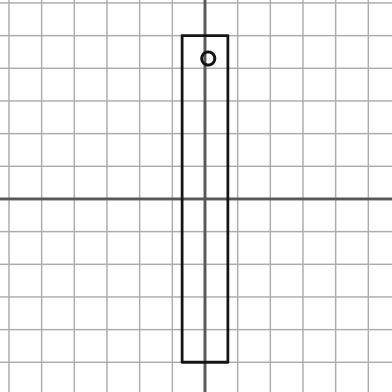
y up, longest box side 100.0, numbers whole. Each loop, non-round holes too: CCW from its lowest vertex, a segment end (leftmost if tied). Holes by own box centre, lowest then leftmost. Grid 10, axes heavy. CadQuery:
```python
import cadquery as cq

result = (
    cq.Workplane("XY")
    .moveTo(-7.0, -50.0)
    .lineTo(7.0, -50.0)
    .lineTo(7.0, 50.0)
    .lineTo(-7.0, 50.0)
    .close()
    .moveTo(1.0, 43.0)
    .circle(2.0)
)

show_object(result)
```